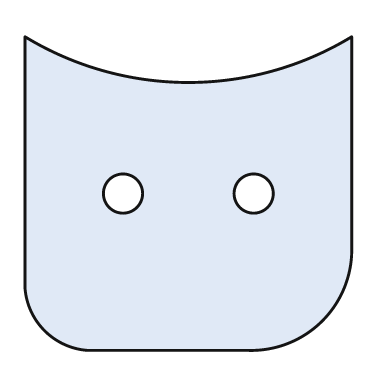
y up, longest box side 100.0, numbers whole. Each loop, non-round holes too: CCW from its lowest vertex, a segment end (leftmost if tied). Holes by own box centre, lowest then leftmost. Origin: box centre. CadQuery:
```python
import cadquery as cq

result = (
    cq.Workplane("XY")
    .moveTo(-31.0, -48.0)
    .lineTo(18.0, -48.0)
    .threePointArc((41.0, -39.0), (50.0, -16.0))
    .lineTo(50.0, 48.0)
    .threePointArc((0.0, 34.0), (-50.0, 48.0))
    .lineTo(-50.0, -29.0)
    .threePointArc((-44.0, -42.0), (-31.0, -48.0))
    .close()
    .moveTo(-20.0, 0.0)
    .circle(6.0)
    .moveTo(20.0, 0.0)
    .circle(6.0)
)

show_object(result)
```